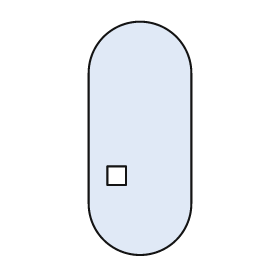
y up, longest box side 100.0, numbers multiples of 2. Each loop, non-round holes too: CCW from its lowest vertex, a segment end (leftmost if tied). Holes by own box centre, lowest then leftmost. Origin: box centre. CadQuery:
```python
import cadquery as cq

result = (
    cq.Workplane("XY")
    .moveTo(-22.0, -28.0)
    .threePointArc((0.0, -50.0), (22.0, -28.0))
    .lineTo(22.0, 28.0)
    .threePointArc((0.0, 50.0), (-22.0, 28.0))
    .close()
    .moveTo(-14.0, -20.0)
    .lineTo(-6.0, -20.0)
    .lineTo(-6.0, -12.0)
    .lineTo(-14.0, -12.0)
    .close()
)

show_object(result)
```